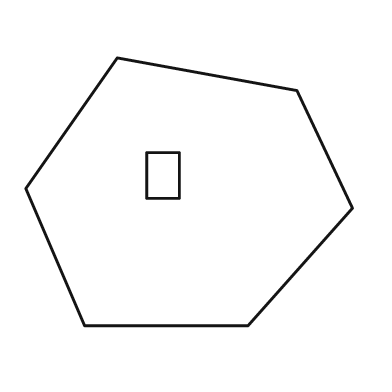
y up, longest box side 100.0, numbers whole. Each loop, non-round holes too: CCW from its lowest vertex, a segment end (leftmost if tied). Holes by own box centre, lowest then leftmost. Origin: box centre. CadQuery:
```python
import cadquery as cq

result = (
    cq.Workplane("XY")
    .moveTo(-32.0, -41.0)
    .lineTo(18.0, -41.0)
    .lineTo(50.0, -5.0)
    .lineTo(33.0, 31.0)
    .lineTo(-22.0, 41.0)
    .lineTo(-50.0, 1.0)
    .close()
    .moveTo(-13.0, -2.0)
    .lineTo(-3.0, -2.0)
    .lineTo(-3.0, 12.0)
    .lineTo(-13.0, 12.0)
    .close()
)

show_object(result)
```